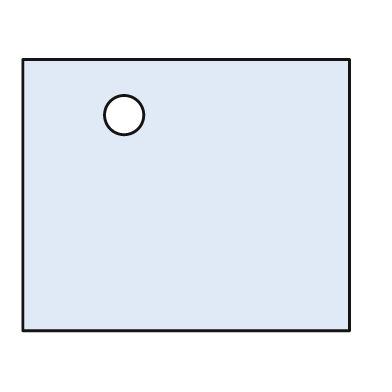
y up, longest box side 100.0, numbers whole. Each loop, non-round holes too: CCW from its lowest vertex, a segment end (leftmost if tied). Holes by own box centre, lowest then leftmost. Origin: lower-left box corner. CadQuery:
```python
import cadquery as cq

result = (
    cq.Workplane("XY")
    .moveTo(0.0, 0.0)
    .lineTo(100.0, 0.0)
    .lineTo(100.0, 83.0)
    .lineTo(0.0, 83.0)
    .close()
    .moveTo(31.0, 66.0)
    .circle(6.0)
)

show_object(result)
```